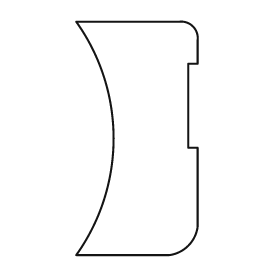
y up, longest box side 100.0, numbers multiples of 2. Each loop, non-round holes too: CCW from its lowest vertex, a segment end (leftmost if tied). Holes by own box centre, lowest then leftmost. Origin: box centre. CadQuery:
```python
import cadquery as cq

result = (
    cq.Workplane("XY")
    .moveTo(-26.0, -50.0)
    .lineTo(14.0, -50.0)
    .threePointArc((22.0, -46.0), (26.0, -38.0))
    .lineTo(26.0, -4.0)
    .lineTo(22.0, -4.0)
    .lineTo(22.0, 32.0)
    .lineTo(26.0, 32.0)
    .lineTo(26.0, 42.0)
    .threePointArc((24.0, 48.0), (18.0, 50.0))
    .lineTo(-26.0, 50.0)
    .threePointArc((-10.0, 0.0), (-26.0, -50.0))
    .close()
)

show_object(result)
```